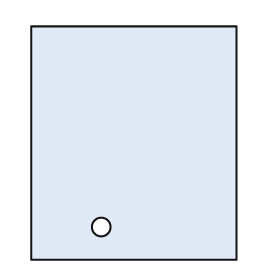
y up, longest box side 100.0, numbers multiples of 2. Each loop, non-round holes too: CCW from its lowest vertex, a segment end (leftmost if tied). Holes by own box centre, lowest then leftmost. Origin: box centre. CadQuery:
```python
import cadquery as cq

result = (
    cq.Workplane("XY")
    .moveTo(-44.0, -50.0)
    .lineTo(44.0, -50.0)
    .lineTo(44.0, 50.0)
    .lineTo(-44.0, 50.0)
    .close()
    .moveTo(-14.0, -36.0)
    .circle(4.0)
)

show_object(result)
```